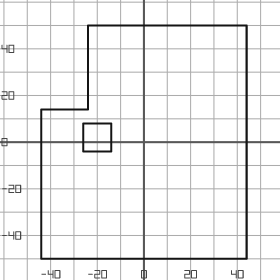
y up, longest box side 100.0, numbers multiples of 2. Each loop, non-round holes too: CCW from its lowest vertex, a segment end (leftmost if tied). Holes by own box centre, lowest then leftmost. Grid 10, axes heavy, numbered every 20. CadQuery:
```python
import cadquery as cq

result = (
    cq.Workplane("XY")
    .moveTo(-44.0, -50.0)
    .lineTo(44.0, -50.0)
    .lineTo(44.0, 50.0)
    .lineTo(-24.0, 50.0)
    .lineTo(-24.0, 14.0)
    .lineTo(-44.0, 14.0)
    .close()
    .moveTo(-26.0, -4.0)
    .lineTo(-14.0, -4.0)
    .lineTo(-14.0, 8.0)
    .lineTo(-26.0, 8.0)
    .close()
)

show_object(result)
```